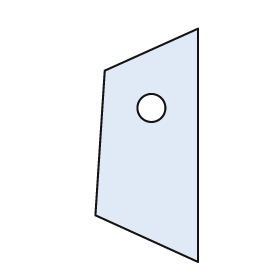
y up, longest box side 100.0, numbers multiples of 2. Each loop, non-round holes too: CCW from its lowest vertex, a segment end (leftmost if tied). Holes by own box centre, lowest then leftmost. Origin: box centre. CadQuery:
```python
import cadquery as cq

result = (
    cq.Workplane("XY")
    .moveTo(22.0, -50.0)
    .lineTo(22.0, 50.0)
    .lineTo(-18.0, 32.0)
    .lineTo(-22.0, -30.0)
    .close()
    .moveTo(2.0, 16.0)
    .circle(6.0)
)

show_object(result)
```